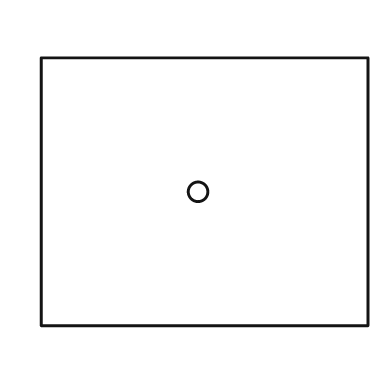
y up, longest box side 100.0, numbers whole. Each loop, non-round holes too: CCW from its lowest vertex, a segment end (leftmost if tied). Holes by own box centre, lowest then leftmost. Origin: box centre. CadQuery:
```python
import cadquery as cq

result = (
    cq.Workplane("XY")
    .moveTo(-50.0, -41.0)
    .lineTo(50.0, -41.0)
    .lineTo(50.0, 41.0)
    .lineTo(-50.0, 41.0)
    .close()
    .moveTo(-2.0, 0.0)
    .circle(3.0)
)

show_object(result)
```